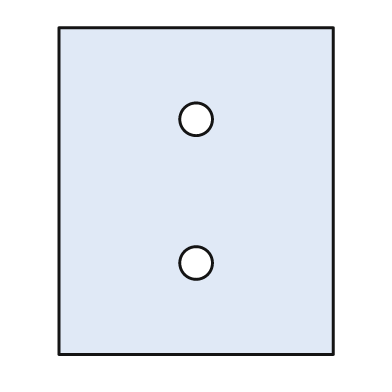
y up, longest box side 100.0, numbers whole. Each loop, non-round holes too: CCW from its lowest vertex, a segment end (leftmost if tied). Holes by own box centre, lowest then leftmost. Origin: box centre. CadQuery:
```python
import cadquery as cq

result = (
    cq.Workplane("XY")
    .moveTo(-42.0, -50.0)
    .lineTo(42.0, -50.0)
    .lineTo(42.0, 50.0)
    .lineTo(-42.0, 50.0)
    .close()
    .moveTo(0.0, -22.0)
    .circle(5.0)
    .moveTo(0.0, 22.0)
    .circle(5.0)
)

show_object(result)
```